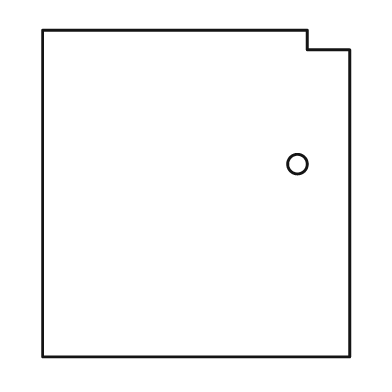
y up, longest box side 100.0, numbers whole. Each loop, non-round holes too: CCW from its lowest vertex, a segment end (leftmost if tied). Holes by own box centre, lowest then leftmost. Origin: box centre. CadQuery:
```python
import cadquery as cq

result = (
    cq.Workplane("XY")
    .moveTo(-47.0, -50.0)
    .lineTo(47.0, -50.0)
    .lineTo(47.0, 44.0)
    .lineTo(34.0, 44.0)
    .lineTo(34.0, 50.0)
    .lineTo(-47.0, 50.0)
    .close()
    .moveTo(31.0, 9.0)
    .circle(3.0)
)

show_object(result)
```